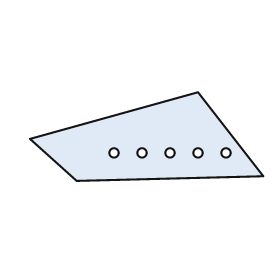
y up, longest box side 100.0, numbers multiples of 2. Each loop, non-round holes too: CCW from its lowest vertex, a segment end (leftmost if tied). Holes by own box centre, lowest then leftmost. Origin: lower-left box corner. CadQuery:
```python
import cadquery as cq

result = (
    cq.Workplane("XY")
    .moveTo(20.0, 0.0)
    .lineTo(100.0, 2.0)
    .lineTo(72.0, 38.0)
    .lineTo(0.0, 18.0)
    .close()
    .moveTo(36.0, 12.0)
    .circle(2.0)
    .moveTo(48.0, 12.0)
    .circle(2.0)
    .moveTo(60.0, 12.0)
    .circle(2.0)
    .moveTo(72.0, 12.0)
    .circle(2.0)
    .moveTo(84.0, 12.0)
    .circle(2.0)
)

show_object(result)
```